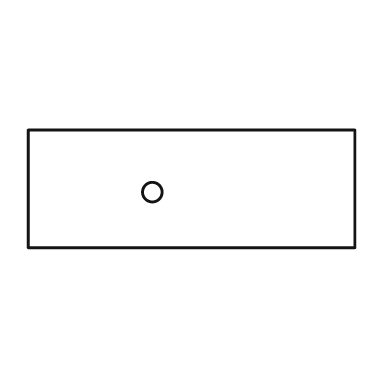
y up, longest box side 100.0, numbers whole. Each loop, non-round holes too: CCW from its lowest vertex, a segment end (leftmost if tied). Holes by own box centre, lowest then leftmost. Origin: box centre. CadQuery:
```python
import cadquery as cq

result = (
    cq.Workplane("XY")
    .moveTo(-50.0, -18.0)
    .lineTo(50.0, -18.0)
    .lineTo(50.0, 18.0)
    .lineTo(-50.0, 18.0)
    .close()
    .moveTo(-12.0, -1.0)
    .circle(3.0)
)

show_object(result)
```